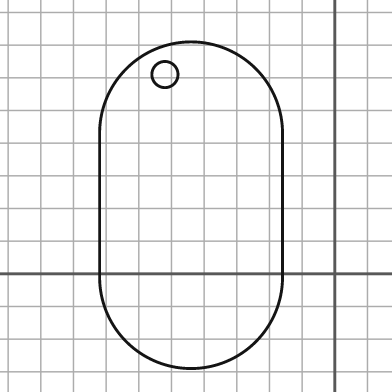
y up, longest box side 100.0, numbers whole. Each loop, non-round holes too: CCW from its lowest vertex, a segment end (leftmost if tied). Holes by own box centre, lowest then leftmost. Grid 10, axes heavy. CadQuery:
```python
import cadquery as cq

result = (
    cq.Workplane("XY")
    .moveTo(-72.0, -1.0)
    .threePointArc((-44.0, -29.0), (-16.0, -1.0))
    .lineTo(-16.0, 43.0)
    .threePointArc((-44.0, 71.0), (-72.0, 43.0))
    .close()
    .moveTo(-52.0, 61.0)
    .circle(4.0)
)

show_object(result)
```